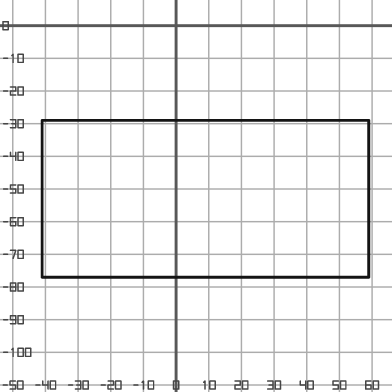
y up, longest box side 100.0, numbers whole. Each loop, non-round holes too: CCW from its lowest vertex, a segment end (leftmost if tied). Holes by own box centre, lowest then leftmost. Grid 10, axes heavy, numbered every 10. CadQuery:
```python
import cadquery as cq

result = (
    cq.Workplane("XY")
    .moveTo(-41.0, -77.0)
    .lineTo(59.0, -77.0)
    .lineTo(59.0, -29.0)
    .lineTo(-41.0, -29.0)
    .close()
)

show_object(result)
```